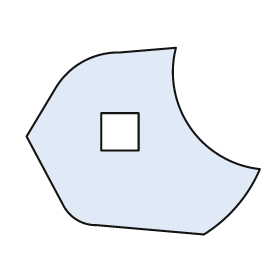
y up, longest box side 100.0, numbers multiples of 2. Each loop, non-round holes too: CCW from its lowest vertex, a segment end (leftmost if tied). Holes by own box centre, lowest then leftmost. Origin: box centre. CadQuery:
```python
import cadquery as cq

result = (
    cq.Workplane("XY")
    .moveTo(26.0, -40.0)
    .threePointArc((40.0, -28.0), (50.0, -12.0))
    .threePointArc((20.0, 6.0), (14.0, 40.0))
    .lineTo(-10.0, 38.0)
    .threePointArc((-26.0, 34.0), (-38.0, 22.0))
    .lineTo(-50.0, 2.0)
    .lineTo(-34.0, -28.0)
    .threePointArc((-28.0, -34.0), (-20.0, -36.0))
    .close()
    .moveTo(-18.0, -4.0)
    .lineTo(-2.0, -4.0)
    .lineTo(-2.0, 12.0)
    .lineTo(-18.0, 12.0)
    .close()
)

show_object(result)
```